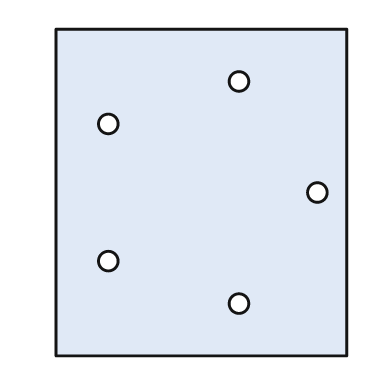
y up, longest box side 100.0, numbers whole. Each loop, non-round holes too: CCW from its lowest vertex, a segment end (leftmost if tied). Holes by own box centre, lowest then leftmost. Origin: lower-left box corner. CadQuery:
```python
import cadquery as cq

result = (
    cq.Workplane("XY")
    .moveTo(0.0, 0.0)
    .lineTo(89.0, 0.0)
    .lineTo(89.0, 100.0)
    .lineTo(0.0, 100.0)
    .close()
    .moveTo(56.0, 16.0)
    .circle(3.0)
    .moveTo(16.0, 29.0)
    .circle(3.0)
    .moveTo(80.0, 50.0)
    .circle(3.0)
    .moveTo(16.0, 71.0)
    .circle(3.0)
    .moveTo(56.0, 84.0)
    .circle(3.0)
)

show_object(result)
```